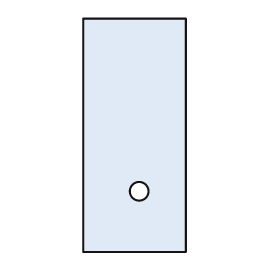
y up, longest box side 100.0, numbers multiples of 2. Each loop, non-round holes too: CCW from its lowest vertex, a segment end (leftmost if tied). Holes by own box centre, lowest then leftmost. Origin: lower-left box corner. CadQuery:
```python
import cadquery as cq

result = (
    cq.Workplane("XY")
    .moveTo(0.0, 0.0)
    .lineTo(44.0, 0.0)
    .lineTo(44.0, 100.0)
    .lineTo(0.0, 100.0)
    .close()
    .moveTo(24.0, 26.0)
    .circle(4.0)
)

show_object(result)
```